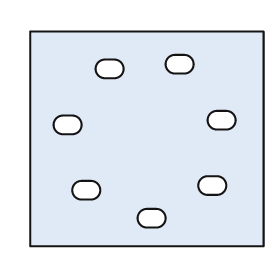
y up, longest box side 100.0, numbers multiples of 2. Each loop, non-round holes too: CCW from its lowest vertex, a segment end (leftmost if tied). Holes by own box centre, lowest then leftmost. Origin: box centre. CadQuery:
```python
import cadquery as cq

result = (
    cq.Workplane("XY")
    .moveTo(-50.0, -46.0)
    .lineTo(50.0, -46.0)
    .lineTo(50.0, 46.0)
    .lineTo(-50.0, 46.0)
    .close()
    .moveTo(0.0, -38.0)
    .lineTo(4.0, -38.0)
    .threePointArc((8.0, -34.0), (4.0, -30.0))
    .lineTo(0.0, -30.0)
    .threePointArc((-4.0, -34.0), (0.0, -38.0))
    .close()
    .moveTo(-28.0, -26.0)
    .lineTo(-24.0, -26.0)
    .threePointArc((-20.0, -22.0), (-24.0, -18.0))
    .lineTo(-28.0, -18.0)
    .threePointArc((-32.0, -22.0), (-28.0, -26.0))
    .close()
    .moveTo(26.0, -24.0)
    .lineTo(30.0, -24.0)
    .threePointArc((34.0, -20.0), (30.0, -16.0))
    .lineTo(26.0, -16.0)
    .threePointArc((22.0, -20.0), (26.0, -24.0))
    .close()
    .moveTo(-36.0, 2.0)
    .lineTo(-32.0, 2.0)
    .threePointArc((-28.0, 6.0), (-32.0, 10.0))
    .lineTo(-36.0, 10.0)
    .threePointArc((-40.0, 6.0), (-36.0, 2.0))
    .close()
    .moveTo(30.0, 4.0)
    .lineTo(34.0, 4.0)
    .threePointArc((38.0, 8.0), (34.0, 12.0))
    .lineTo(30.0, 12.0)
    .threePointArc((26.0, 8.0), (30.0, 4.0))
    .close()
    .moveTo(-18.0, 26.0)
    .lineTo(-14.0, 26.0)
    .threePointArc((-10.0, 30.0), (-14.0, 34.0))
    .lineTo(-18.0, 34.0)
    .threePointArc((-22.0, 30.0), (-18.0, 26.0))
    .close()
    .moveTo(12.0, 28.0)
    .lineTo(16.0, 28.0)
    .threePointArc((20.0, 32.0), (16.0, 36.0))
    .lineTo(12.0, 36.0)
    .threePointArc((8.0, 32.0), (12.0, 28.0))
    .close()
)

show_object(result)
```